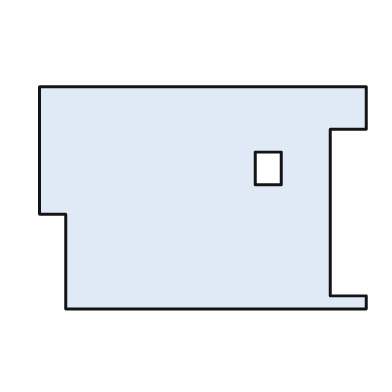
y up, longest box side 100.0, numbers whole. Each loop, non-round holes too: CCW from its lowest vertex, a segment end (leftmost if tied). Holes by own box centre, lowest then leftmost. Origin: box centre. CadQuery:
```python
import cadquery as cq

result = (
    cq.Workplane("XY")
    .moveTo(-42.0, -34.0)
    .lineTo(50.0, -34.0)
    .lineTo(50.0, -30.0)
    .lineTo(39.0, -30.0)
    .lineTo(39.0, 21.0)
    .lineTo(50.0, 21.0)
    .lineTo(50.0, 34.0)
    .lineTo(-50.0, 34.0)
    .lineTo(-50.0, -5.0)
    .lineTo(-42.0, -5.0)
    .close()
    .moveTo(16.0, 4.0)
    .lineTo(24.0, 4.0)
    .lineTo(24.0, 14.0)
    .lineTo(16.0, 14.0)
    .close()
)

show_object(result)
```